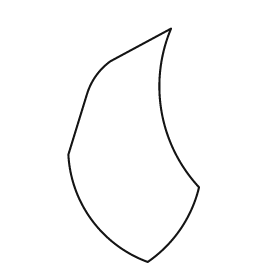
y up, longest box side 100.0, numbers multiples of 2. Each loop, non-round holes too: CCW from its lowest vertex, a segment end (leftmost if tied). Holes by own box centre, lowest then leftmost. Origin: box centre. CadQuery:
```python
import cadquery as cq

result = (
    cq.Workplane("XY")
    .moveTo(6.0, -50.0)
    .threePointArc((20.0, -36.0), (28.0, -18.0))
    .threePointArc((12.0, 14.0), (16.0, 50.0))
    .lineTo(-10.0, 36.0)
    .threePointArc((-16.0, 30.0), (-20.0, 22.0))
    .lineTo(-28.0, -4.0)
    .threePointArc((-18.0, -32.0), (6.0, -50.0))
    .close()
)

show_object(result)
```